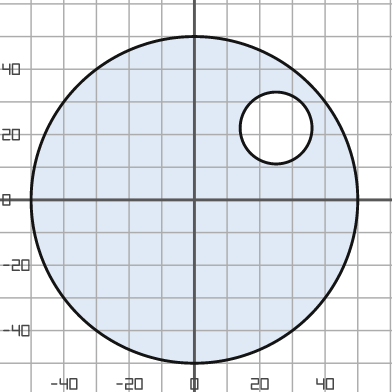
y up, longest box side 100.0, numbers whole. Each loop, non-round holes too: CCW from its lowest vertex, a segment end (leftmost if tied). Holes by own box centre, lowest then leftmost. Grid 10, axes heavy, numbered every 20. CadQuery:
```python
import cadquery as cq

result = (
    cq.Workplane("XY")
    .moveTo(0.0, 0.0)
    .circle(50.0)
    .moveTo(25.0, 22.0)
    .circle(11.0)
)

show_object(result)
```